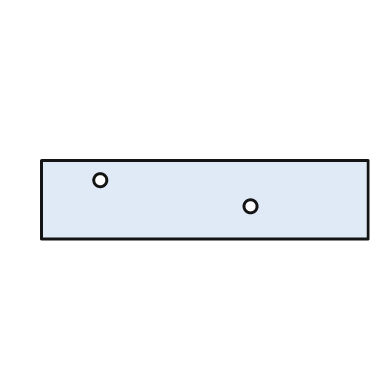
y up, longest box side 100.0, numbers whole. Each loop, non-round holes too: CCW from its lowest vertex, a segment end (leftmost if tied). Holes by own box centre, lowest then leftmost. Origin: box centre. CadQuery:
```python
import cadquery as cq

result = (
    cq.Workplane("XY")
    .moveTo(-50.0, -12.0)
    .lineTo(50.0, -12.0)
    .lineTo(50.0, 12.0)
    .lineTo(-50.0, 12.0)
    .close()
    .moveTo(14.0, -2.0)
    .circle(2.0)
    .moveTo(-32.0, 6.0)
    .circle(2.0)
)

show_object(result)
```